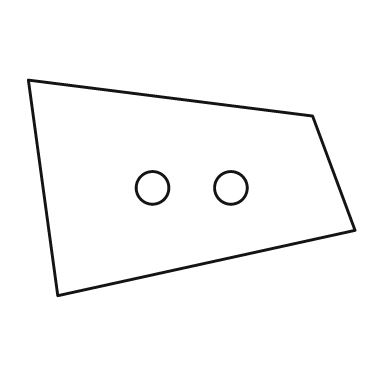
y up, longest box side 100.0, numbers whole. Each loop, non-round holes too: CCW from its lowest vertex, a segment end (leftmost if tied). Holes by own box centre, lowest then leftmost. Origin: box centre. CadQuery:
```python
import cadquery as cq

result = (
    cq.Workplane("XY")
    .moveTo(-41.0, -33.0)
    .lineTo(50.0, -13.0)
    .lineTo(37.0, 22.0)
    .lineTo(-50.0, 33.0)
    .close()
    .moveTo(-12.0, 0.0)
    .circle(5.0)
    .moveTo(12.0, 0.0)
    .circle(5.0)
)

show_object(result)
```